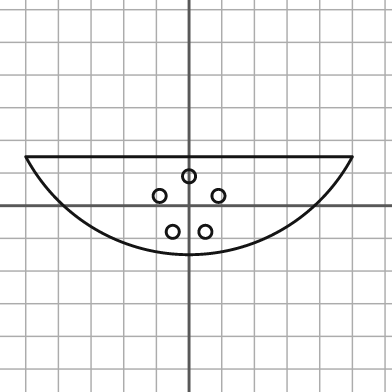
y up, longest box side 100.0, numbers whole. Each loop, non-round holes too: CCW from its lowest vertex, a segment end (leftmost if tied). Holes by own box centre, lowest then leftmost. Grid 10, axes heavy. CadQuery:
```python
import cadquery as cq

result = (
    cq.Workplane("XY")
    .moveTo(-50.0, 15.0)
    .threePointArc((0.0, -15.0), (50.0, 15.0))
    .close()
    .moveTo(-5.0, -8.0)
    .circle(2.0)
    .moveTo(5.0, -8.0)
    .circle(2.0)
    .moveTo(-9.0, 3.0)
    .circle(2.0)
    .moveTo(9.0, 3.0)
    .circle(2.0)
    .moveTo(0.0, 9.0)
    .circle(2.0)
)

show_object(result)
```